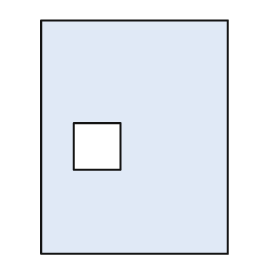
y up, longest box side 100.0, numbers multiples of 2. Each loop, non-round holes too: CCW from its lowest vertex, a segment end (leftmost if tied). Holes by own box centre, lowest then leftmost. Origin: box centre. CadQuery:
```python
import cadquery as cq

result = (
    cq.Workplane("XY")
    .moveTo(-40.0, -50.0)
    .lineTo(40.0, -50.0)
    .lineTo(40.0, 50.0)
    .lineTo(-40.0, 50.0)
    .close()
    .moveTo(-26.0, -14.0)
    .lineTo(-6.0, -14.0)
    .lineTo(-6.0, 6.0)
    .lineTo(-26.0, 6.0)
    .close()
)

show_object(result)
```